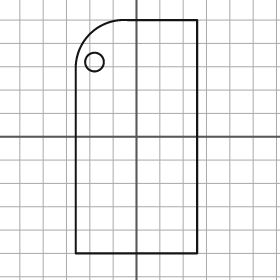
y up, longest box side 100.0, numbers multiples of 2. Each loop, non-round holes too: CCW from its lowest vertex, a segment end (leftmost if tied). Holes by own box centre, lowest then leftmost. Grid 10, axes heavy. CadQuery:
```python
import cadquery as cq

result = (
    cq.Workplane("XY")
    .moveTo(-26.0, -50.0)
    .lineTo(26.0, -50.0)
    .lineTo(26.0, 50.0)
    .lineTo(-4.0, 50.0)
    .threePointArc((-20.0, 44.0), (-26.0, 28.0))
    .close()
    .moveTo(-18.0, 32.0)
    .circle(4.0)
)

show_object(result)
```